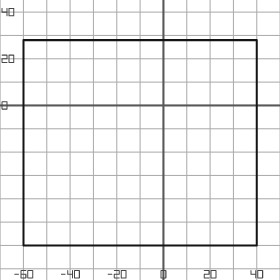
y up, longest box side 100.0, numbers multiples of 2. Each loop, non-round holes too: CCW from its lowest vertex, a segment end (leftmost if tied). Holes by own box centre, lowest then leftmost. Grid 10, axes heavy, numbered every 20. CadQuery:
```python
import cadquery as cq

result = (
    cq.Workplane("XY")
    .moveTo(-60.0, -60.0)
    .lineTo(40.0, -60.0)
    .lineTo(40.0, 28.0)
    .lineTo(-60.0, 28.0)
    .close()
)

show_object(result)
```